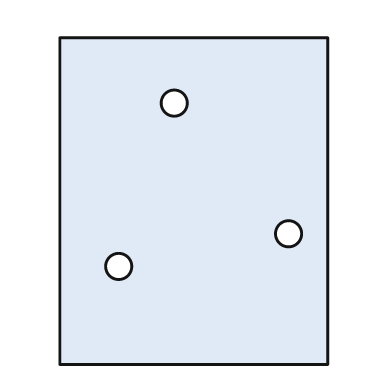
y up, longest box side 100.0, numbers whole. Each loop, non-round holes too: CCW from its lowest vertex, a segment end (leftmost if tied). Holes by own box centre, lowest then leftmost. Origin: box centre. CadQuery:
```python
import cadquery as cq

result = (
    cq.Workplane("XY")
    .moveTo(-41.0, -50.0)
    .lineTo(41.0, -50.0)
    .lineTo(41.0, 50.0)
    .lineTo(-41.0, 50.0)
    .close()
    .moveTo(-23.0, -20.0)
    .circle(4.0)
    .moveTo(29.0, -10.0)
    .circle(4.0)
    .moveTo(-6.0, 30.0)
    .circle(4.0)
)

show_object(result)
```